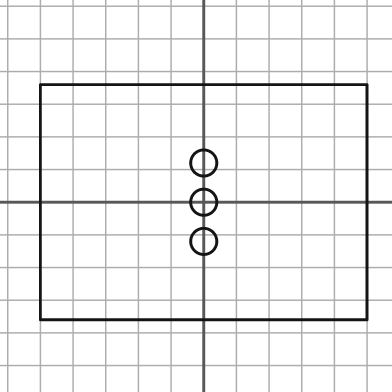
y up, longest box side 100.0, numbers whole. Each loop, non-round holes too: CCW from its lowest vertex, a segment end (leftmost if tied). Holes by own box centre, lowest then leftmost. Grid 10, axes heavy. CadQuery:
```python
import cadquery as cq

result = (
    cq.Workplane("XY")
    .moveTo(-50.0, -36.0)
    .lineTo(50.0, -36.0)
    .lineTo(50.0, 36.0)
    .lineTo(-50.0, 36.0)
    .close()
    .moveTo(0.0, -12.0)
    .circle(4.0)
    .moveTo(0.0, 0.0)
    .circle(4.0)
    .moveTo(0.0, 12.0)
    .circle(4.0)
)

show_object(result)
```